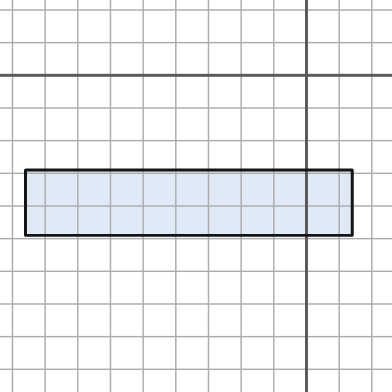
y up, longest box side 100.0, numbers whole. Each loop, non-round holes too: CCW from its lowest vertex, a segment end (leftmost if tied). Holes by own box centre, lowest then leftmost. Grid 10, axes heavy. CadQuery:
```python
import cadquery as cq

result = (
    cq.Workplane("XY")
    .moveTo(-86.0, -49.0)
    .lineTo(14.0, -49.0)
    .lineTo(14.0, -29.0)
    .lineTo(-86.0, -29.0)
    .close()
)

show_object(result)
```